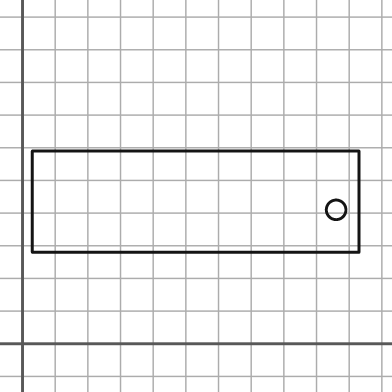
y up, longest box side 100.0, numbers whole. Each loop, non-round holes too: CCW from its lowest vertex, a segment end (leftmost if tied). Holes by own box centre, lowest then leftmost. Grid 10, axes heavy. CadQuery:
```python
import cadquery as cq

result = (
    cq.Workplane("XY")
    .moveTo(3.0, 28.0)
    .lineTo(103.0, 28.0)
    .lineTo(103.0, 59.0)
    .lineTo(3.0, 59.0)
    .close()
    .moveTo(96.0, 41.0)
    .circle(3.0)
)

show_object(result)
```